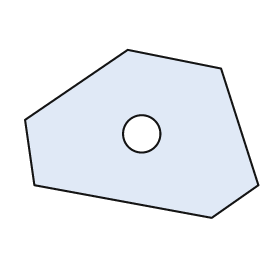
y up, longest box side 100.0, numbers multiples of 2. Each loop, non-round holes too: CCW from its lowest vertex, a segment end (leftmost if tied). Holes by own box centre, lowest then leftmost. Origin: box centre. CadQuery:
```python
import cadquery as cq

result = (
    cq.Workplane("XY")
    .moveTo(30.0, -36.0)
    .lineTo(50.0, -22.0)
    .lineTo(34.0, 28.0)
    .lineTo(-6.0, 36.0)
    .lineTo(-50.0, 6.0)
    .lineTo(-46.0, -22.0)
    .close()
    .moveTo(0.0, 0.0)
    .circle(8.0)
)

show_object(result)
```